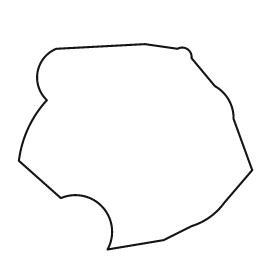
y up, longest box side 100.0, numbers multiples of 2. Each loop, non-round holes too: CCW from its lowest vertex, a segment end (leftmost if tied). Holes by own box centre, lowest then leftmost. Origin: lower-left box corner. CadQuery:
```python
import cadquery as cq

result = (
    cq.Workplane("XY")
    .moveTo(38.0, 0.0)
    .lineTo(62.0, 4.0)
    .lineTo(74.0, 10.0)
    .threePointArc((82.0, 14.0), (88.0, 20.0))
    .lineTo(100.0, 34.0)
    .lineTo(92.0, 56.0)
    .threePointArc((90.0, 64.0), (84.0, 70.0))
    .lineTo(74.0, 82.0)
    .threePointArc((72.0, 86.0), (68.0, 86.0))
    .lineTo(54.0, 88.0)
    .lineTo(16.0, 86.0)
    .threePointArc((8.0, 76.0), (12.0, 64.0))
    .threePointArc((4.0, 52.0), (0.0, 38.0))
    .lineTo(18.0, 22.0)
    .threePointArc((36.0, 18.0), (38.0, 0.0))
    .close()
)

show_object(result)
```